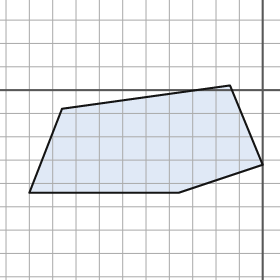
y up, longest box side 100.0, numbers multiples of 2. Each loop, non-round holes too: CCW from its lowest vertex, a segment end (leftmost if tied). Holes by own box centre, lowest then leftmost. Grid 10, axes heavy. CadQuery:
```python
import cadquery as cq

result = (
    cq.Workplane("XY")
    .moveTo(-100.0, -44.0)
    .lineTo(-36.0, -44.0)
    .lineTo(0.0, -32.0)
    .lineTo(-14.0, 2.0)
    .lineTo(-86.0, -8.0)
    .close()
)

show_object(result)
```